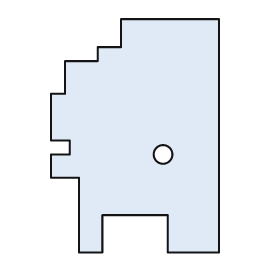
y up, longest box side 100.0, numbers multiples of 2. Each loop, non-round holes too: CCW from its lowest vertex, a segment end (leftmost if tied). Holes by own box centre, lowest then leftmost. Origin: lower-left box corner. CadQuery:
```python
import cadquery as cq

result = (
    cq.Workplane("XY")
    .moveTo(12.0, 0.0)
    .lineTo(22.0, 0.0)
    .lineTo(22.0, 16.0)
    .lineTo(50.0, 16.0)
    .lineTo(50.0, 0.0)
    .lineTo(72.0, 0.0)
    .lineTo(72.0, 100.0)
    .lineTo(30.0, 100.0)
    .lineTo(30.0, 88.0)
    .lineTo(20.0, 88.0)
    .lineTo(20.0, 82.0)
    .lineTo(6.0, 82.0)
    .lineTo(6.0, 68.0)
    .lineTo(0.0, 68.0)
    .lineTo(0.0, 48.0)
    .lineTo(8.0, 48.0)
    .lineTo(8.0, 42.0)
    .lineTo(0.0, 42.0)
    .lineTo(0.0, 32.0)
    .lineTo(12.0, 32.0)
    .close()
    .moveTo(48.0, 42.0)
    .circle(4.0)
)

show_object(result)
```